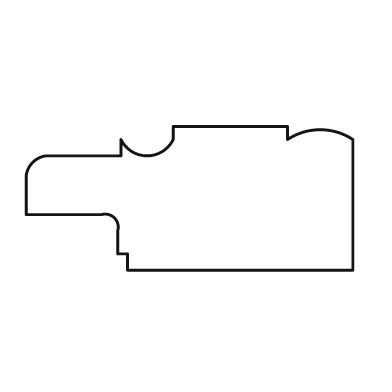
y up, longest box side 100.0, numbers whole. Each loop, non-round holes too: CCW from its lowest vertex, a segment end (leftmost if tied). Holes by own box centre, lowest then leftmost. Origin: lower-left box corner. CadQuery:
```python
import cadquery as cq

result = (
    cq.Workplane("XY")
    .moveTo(31.0, 0.0)
    .lineTo(100.0, 0.0)
    .lineTo(100.0, 40.0)
    .threePointArc((90.0, 43.0), (80.0, 40.0))
    .lineTo(80.0, 44.0)
    .lineTo(45.0, 44.0)
    .lineTo(45.0, 40.0)
    .threePointArc((37.0, 35.0), (29.0, 40.0))
    .lineTo(29.0, 35.0)
    .lineTo(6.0, 35.0)
    .threePointArc((2.0, 33.0), (0.0, 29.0))
    .lineTo(0.0, 17.0)
    .lineTo(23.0, 17.0)
    .threePointArc((27.0, 16.0), (28.0, 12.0))
    .lineTo(28.0, 5.0)
    .lineTo(31.0, 5.0)
    .close()
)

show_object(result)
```